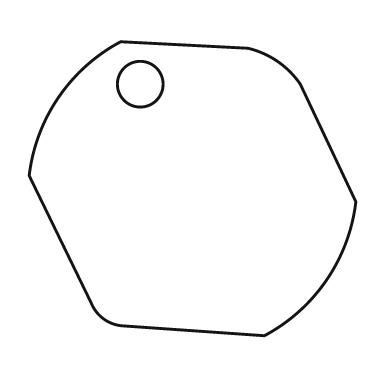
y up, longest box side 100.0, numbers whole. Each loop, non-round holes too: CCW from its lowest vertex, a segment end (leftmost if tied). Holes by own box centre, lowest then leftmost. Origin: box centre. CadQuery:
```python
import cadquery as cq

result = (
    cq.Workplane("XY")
    .moveTo(22.0, -45.0)
    .threePointArc((41.0, -28.0), (50.0, -4.0))
    .lineTo(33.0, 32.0)
    .threePointArc((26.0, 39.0), (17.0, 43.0))
    .lineTo(-22.0, 45.0)
    .threePointArc((-41.0, 28.0), (-50.0, 4.0))
    .lineTo(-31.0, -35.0)
    .threePointArc((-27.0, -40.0), (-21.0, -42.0))
    .close()
    .moveTo(-16.0, 32.0)
    .circle(7.0)
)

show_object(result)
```